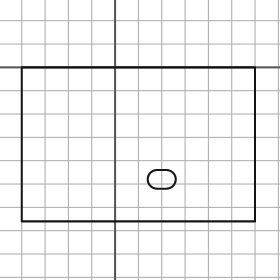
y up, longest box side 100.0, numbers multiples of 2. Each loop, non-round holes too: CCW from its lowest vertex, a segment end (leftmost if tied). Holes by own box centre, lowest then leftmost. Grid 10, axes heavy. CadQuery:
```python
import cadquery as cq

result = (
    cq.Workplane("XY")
    .moveTo(-40.0, -66.0)
    .lineTo(60.0, -66.0)
    .lineTo(60.0, 0.0)
    .lineTo(-40.0, 0.0)
    .close()
    .moveTo(18.0, -52.0)
    .lineTo(22.0, -52.0)
    .threePointArc((26.0, -48.0), (22.0, -44.0))
    .lineTo(18.0, -44.0)
    .threePointArc((14.0, -48.0), (18.0, -52.0))
    .close()
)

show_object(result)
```